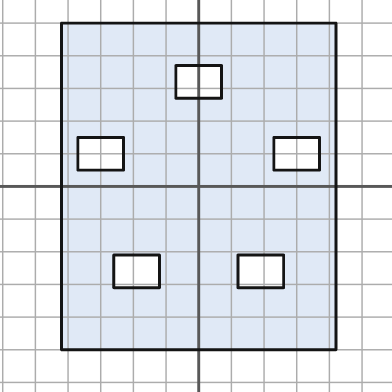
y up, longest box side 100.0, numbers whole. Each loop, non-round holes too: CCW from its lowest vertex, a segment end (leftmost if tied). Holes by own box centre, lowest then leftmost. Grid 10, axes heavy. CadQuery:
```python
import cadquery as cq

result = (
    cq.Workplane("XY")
    .moveTo(-42.0, -50.0)
    .lineTo(42.0, -50.0)
    .lineTo(42.0, 50.0)
    .lineTo(-42.0, 50.0)
    .close()
    .moveTo(-26.0, -31.0)
    .lineTo(-12.0, -31.0)
    .lineTo(-12.0, -21.0)
    .lineTo(-26.0, -21.0)
    .close()
    .moveTo(12.0, -31.0)
    .lineTo(26.0, -31.0)
    .lineTo(26.0, -21.0)
    .lineTo(12.0, -21.0)
    .close()
    .moveTo(-37.0, 5.0)
    .lineTo(-23.0, 5.0)
    .lineTo(-23.0, 15.0)
    .lineTo(-37.0, 15.0)
    .close()
    .moveTo(23.0, 5.0)
    .lineTo(37.0, 5.0)
    .lineTo(37.0, 15.0)
    .lineTo(23.0, 15.0)
    .close()
    .moveTo(-7.0, 27.0)
    .lineTo(7.0, 27.0)
    .lineTo(7.0, 37.0)
    .lineTo(-7.0, 37.0)
    .close()
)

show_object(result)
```